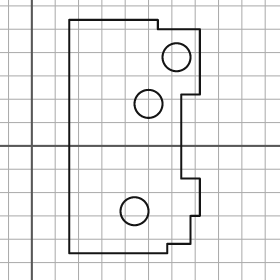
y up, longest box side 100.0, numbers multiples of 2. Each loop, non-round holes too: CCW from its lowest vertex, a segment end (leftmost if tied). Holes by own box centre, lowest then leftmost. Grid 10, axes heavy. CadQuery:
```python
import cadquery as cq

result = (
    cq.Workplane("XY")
    .moveTo(16.0, -46.0)
    .lineTo(58.0, -46.0)
    .lineTo(58.0, -42.0)
    .lineTo(68.0, -42.0)
    .lineTo(68.0, -30.0)
    .lineTo(72.0, -30.0)
    .lineTo(72.0, -14.0)
    .lineTo(64.0, -14.0)
    .lineTo(64.0, 22.0)
    .lineTo(72.0, 22.0)
    .lineTo(72.0, 50.0)
    .lineTo(54.0, 50.0)
    .lineTo(54.0, 54.0)
    .lineTo(16.0, 54.0)
    .close()
    .moveTo(44.0, -28.0)
    .circle(6.0)
    .moveTo(50.0, 18.0)
    .circle(6.0)
    .moveTo(62.0, 38.0)
    .circle(6.0)
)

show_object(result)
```